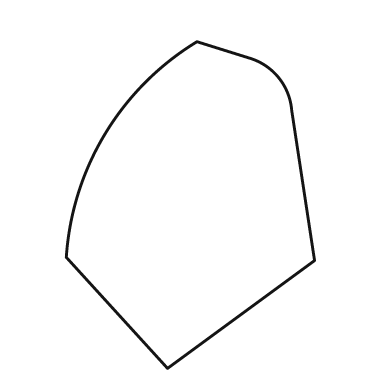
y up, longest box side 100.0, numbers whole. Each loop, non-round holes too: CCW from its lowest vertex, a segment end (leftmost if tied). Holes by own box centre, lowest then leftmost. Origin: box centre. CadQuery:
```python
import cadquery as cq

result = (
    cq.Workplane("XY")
    .moveTo(-7.0, -50.0)
    .lineTo(38.0, -17.0)
    .lineTo(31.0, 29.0)
    .threePointArc((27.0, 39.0), (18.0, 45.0))
    .lineTo(2.0, 50.0)
    .threePointArc((-26.0, 22.0), (-38.0, -16.0))
    .close()
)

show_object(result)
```